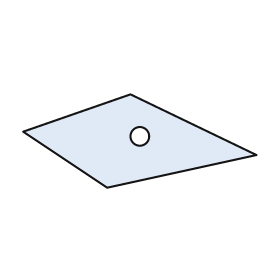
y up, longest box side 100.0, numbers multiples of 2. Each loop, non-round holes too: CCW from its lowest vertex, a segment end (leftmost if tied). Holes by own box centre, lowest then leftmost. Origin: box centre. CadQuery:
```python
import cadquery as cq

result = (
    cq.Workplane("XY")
    .moveTo(-14.0, -20.0)
    .lineTo(50.0, -6.0)
    .lineTo(-4.0, 20.0)
    .lineTo(-50.0, 4.0)
    .close()
    .moveTo(0.0, 2.0)
    .circle(4.0)
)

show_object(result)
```